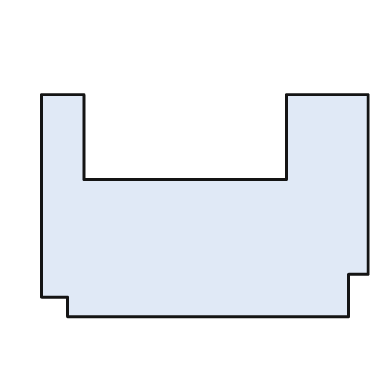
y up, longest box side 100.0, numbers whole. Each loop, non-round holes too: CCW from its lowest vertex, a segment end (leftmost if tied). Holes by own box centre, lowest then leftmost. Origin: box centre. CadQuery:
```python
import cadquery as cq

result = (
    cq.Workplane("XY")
    .moveTo(-42.0, -34.0)
    .lineTo(44.0, -34.0)
    .lineTo(44.0, -21.0)
    .lineTo(50.0, -21.0)
    .lineTo(50.0, 34.0)
    .lineTo(25.0, 34.0)
    .lineTo(25.0, 8.0)
    .lineTo(-37.0, 8.0)
    .lineTo(-37.0, 34.0)
    .lineTo(-50.0, 34.0)
    .lineTo(-50.0, -28.0)
    .lineTo(-42.0, -28.0)
    .close()
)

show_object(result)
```